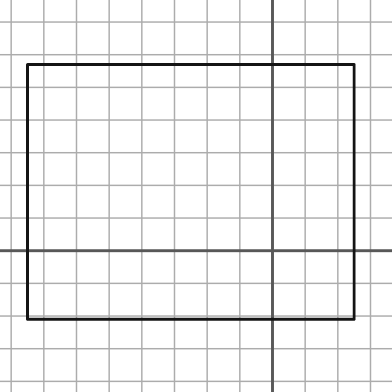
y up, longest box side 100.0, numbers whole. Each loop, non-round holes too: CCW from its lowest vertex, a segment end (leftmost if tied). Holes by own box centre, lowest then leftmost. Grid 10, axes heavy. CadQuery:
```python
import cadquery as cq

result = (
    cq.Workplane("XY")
    .moveTo(-75.0, -21.0)
    .lineTo(25.0, -21.0)
    .lineTo(25.0, 57.0)
    .lineTo(-75.0, 57.0)
    .close()
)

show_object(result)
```